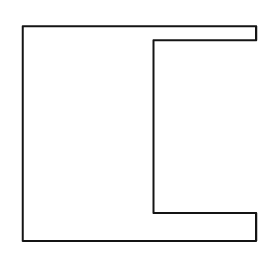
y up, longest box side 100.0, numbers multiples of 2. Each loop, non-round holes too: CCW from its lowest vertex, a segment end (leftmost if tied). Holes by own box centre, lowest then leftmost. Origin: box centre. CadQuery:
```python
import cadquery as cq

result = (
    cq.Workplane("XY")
    .moveTo(-50.0, -46.0)
    .lineTo(50.0, -46.0)
    .lineTo(50.0, -34.0)
    .lineTo(6.0, -34.0)
    .lineTo(6.0, 40.0)
    .lineTo(50.0, 40.0)
    .lineTo(50.0, 46.0)
    .lineTo(-50.0, 46.0)
    .close()
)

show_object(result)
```